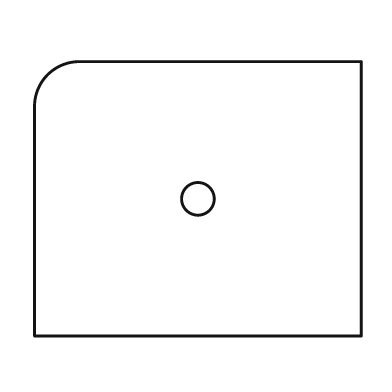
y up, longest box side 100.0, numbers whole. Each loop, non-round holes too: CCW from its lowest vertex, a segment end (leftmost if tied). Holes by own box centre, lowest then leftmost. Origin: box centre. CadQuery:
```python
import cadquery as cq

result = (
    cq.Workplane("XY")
    .moveTo(-50.0, -42.0)
    .lineTo(50.0, -42.0)
    .lineTo(50.0, 42.0)
    .lineTo(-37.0, 42.0)
    .threePointArc((-46.0, 38.0), (-50.0, 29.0))
    .close()
    .moveTo(0.0, 0.0)
    .circle(5.0)
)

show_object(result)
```